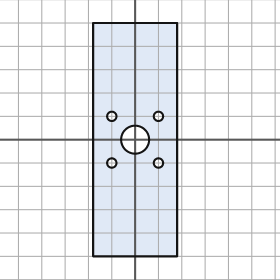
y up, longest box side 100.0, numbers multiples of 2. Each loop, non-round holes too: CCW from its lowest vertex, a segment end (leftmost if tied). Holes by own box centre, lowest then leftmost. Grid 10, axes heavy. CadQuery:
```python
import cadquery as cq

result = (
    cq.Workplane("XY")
    .moveTo(-18.0, -50.0)
    .lineTo(18.0, -50.0)
    .lineTo(18.0, 50.0)
    .lineTo(-18.0, 50.0)
    .close()
    .moveTo(-10.0, -10.0)
    .circle(2.0)
    .moveTo(10.0, -10.0)
    .circle(2.0)
    .moveTo(0.0, 0.0)
    .circle(6.0)
    .moveTo(-10.0, 10.0)
    .circle(2.0)
    .moveTo(10.0, 10.0)
    .circle(2.0)
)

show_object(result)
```